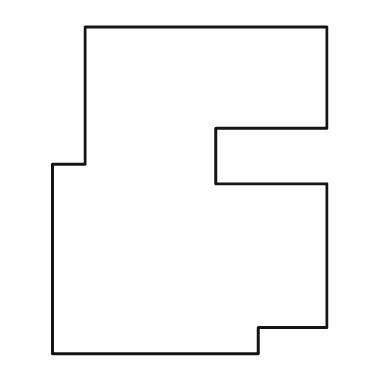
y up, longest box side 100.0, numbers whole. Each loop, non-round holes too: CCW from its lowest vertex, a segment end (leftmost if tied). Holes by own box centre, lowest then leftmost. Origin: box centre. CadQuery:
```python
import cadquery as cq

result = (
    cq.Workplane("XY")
    .moveTo(-42.0, -50.0)
    .lineTo(21.0, -50.0)
    .lineTo(21.0, -42.0)
    .lineTo(42.0, -42.0)
    .lineTo(42.0, 2.0)
    .lineTo(8.0, 2.0)
    .lineTo(8.0, 19.0)
    .lineTo(42.0, 19.0)
    .lineTo(42.0, 50.0)
    .lineTo(-32.0, 50.0)
    .lineTo(-32.0, 8.0)
    .lineTo(-42.0, 8.0)
    .close()
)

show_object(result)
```